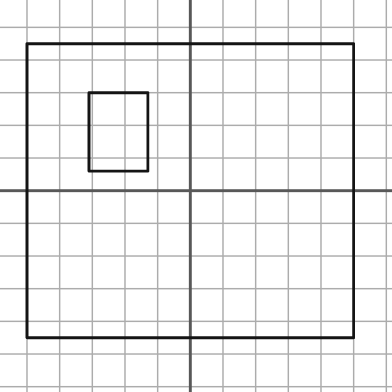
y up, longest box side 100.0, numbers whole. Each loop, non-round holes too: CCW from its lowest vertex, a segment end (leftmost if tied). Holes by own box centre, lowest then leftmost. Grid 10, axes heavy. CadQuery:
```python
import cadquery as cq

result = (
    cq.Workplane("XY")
    .moveTo(-50.0, -45.0)
    .lineTo(50.0, -45.0)
    .lineTo(50.0, 45.0)
    .lineTo(-50.0, 45.0)
    .close()
    .moveTo(-31.0, 6.0)
    .lineTo(-13.0, 6.0)
    .lineTo(-13.0, 30.0)
    .lineTo(-31.0, 30.0)
    .close()
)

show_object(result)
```